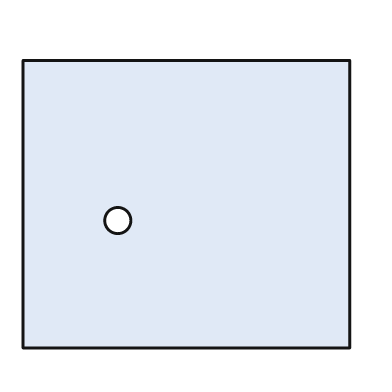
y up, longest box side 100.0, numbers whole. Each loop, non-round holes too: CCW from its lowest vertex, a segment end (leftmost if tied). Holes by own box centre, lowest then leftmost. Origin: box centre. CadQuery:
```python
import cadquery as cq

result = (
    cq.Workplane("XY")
    .moveTo(-50.0, -44.0)
    .lineTo(50.0, -44.0)
    .lineTo(50.0, 44.0)
    .lineTo(-50.0, 44.0)
    .close()
    .moveTo(-21.0, -5.0)
    .circle(4.0)
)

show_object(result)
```